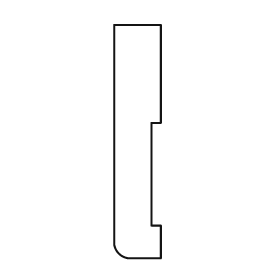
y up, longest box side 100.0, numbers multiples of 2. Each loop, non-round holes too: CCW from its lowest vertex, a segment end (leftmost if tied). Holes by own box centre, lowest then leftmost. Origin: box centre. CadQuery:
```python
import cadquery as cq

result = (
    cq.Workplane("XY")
    .moveTo(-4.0, -50.0)
    .lineTo(10.0, -50.0)
    .lineTo(10.0, -36.0)
    .lineTo(6.0, -36.0)
    .lineTo(6.0, 8.0)
    .lineTo(10.0, 8.0)
    .lineTo(10.0, 50.0)
    .lineTo(-10.0, 50.0)
    .lineTo(-10.0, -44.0)
    .threePointArc((-8.0, -48.0), (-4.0, -50.0))
    .close()
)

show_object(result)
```